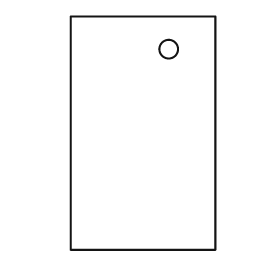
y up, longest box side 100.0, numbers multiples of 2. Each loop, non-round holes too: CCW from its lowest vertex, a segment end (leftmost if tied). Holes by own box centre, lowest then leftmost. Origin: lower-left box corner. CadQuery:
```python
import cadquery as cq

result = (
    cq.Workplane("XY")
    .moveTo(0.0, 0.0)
    .lineTo(62.0, 0.0)
    .lineTo(62.0, 100.0)
    .lineTo(0.0, 100.0)
    .close()
    .moveTo(42.0, 86.0)
    .circle(4.0)
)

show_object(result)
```